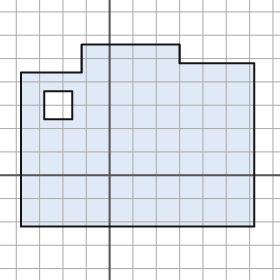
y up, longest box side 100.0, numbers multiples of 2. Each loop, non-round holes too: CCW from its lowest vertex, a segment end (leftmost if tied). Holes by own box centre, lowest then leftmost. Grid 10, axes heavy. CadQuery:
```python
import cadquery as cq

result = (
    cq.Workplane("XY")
    .moveTo(-38.0, -22.0)
    .lineTo(62.0, -22.0)
    .lineTo(62.0, 48.0)
    .lineTo(30.0, 48.0)
    .lineTo(30.0, 56.0)
    .lineTo(-12.0, 56.0)
    .lineTo(-12.0, 44.0)
    .lineTo(-38.0, 44.0)
    .close()
    .moveTo(-28.0, 24.0)
    .lineTo(-16.0, 24.0)
    .lineTo(-16.0, 36.0)
    .lineTo(-28.0, 36.0)
    .close()
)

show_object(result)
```